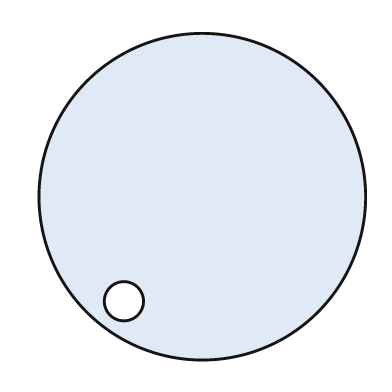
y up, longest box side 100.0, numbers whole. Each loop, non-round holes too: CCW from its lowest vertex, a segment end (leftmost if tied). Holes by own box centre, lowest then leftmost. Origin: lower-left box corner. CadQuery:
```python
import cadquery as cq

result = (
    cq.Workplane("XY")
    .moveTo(50.0, 50.0)
    .circle(50.0)
    .moveTo(26.0, 18.0)
    .circle(6.0)
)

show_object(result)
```